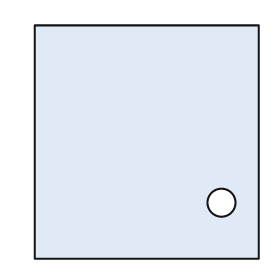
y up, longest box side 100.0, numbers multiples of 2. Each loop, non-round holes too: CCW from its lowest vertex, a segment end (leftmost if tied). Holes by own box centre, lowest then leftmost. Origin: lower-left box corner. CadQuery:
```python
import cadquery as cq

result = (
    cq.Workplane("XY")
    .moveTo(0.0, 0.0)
    .lineTo(96.0, 0.0)
    .lineTo(96.0, 100.0)
    .lineTo(0.0, 100.0)
    .close()
    .moveTo(80.0, 24.0)
    .circle(6.0)
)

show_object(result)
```